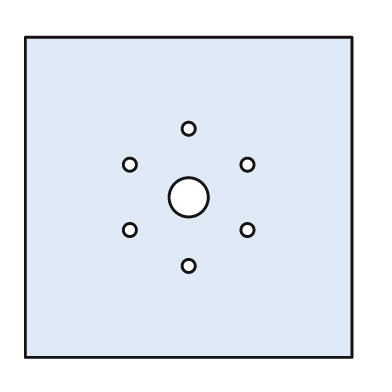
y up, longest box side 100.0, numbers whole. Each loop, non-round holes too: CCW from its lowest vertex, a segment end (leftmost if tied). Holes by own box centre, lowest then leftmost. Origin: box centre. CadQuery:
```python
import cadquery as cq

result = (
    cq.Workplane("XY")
    .moveTo(-50.0, -49.0)
    .lineTo(50.0, -49.0)
    .lineTo(50.0, 49.0)
    .lineTo(-50.0, 49.0)
    .close()
    .moveTo(0.0, -21.0)
    .circle(2.0)
    .moveTo(-18.0, -10.0)
    .circle(2.0)
    .moveTo(18.0, -10.0)
    .circle(2.0)
    .moveTo(0.0, 0.0)
    .circle(6.0)
    .moveTo(-18.0, 10.0)
    .circle(2.0)
    .moveTo(18.0, 10.0)
    .circle(2.0)
    .moveTo(0.0, 21.0)
    .circle(2.0)
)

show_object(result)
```